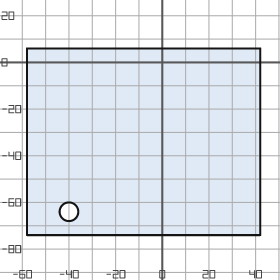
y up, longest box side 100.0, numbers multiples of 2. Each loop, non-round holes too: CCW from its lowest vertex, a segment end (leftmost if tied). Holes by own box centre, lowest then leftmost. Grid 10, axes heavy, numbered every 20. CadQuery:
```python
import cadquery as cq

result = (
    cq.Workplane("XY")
    .moveTo(-58.0, -74.0)
    .lineTo(42.0, -74.0)
    .lineTo(42.0, 6.0)
    .lineTo(-58.0, 6.0)
    .close()
    .moveTo(-40.0, -64.0)
    .circle(4.0)
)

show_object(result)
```